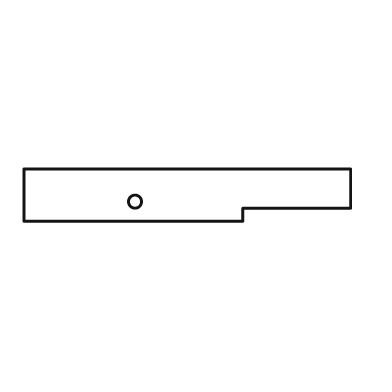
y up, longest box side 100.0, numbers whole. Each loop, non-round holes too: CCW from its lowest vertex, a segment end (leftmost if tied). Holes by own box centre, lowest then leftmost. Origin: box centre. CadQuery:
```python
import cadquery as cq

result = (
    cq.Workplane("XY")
    .moveTo(-50.0, -8.0)
    .lineTo(17.0, -8.0)
    .lineTo(17.0, -4.0)
    .lineTo(50.0, -4.0)
    .lineTo(50.0, 8.0)
    .lineTo(-50.0, 8.0)
    .close()
    .moveTo(-16.0, -2.0)
    .circle(2.0)
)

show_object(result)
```